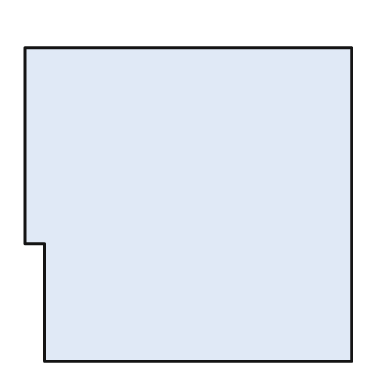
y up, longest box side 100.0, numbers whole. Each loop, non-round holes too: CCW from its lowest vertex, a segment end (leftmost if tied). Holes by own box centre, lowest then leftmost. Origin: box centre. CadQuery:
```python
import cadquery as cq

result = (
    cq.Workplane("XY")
    .moveTo(-44.0, -48.0)
    .lineTo(50.0, -48.0)
    .lineTo(50.0, 48.0)
    .lineTo(-50.0, 48.0)
    .lineTo(-50.0, -12.0)
    .lineTo(-44.0, -12.0)
    .close()
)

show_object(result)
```